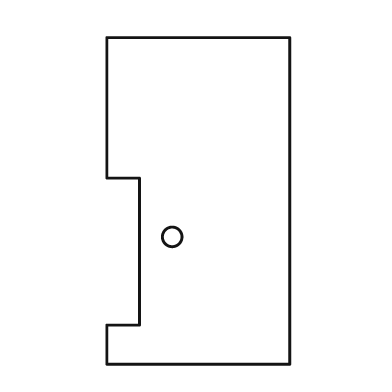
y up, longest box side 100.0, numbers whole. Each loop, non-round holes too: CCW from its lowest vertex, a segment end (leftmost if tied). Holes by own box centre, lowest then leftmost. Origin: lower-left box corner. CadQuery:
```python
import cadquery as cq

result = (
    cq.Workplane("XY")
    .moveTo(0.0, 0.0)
    .lineTo(56.0, 0.0)
    .lineTo(56.0, 100.0)
    .lineTo(0.0, 100.0)
    .lineTo(0.0, 57.0)
    .lineTo(10.0, 57.0)
    .lineTo(10.0, 12.0)
    .lineTo(0.0, 12.0)
    .close()
    .moveTo(20.0, 39.0)
    .circle(3.0)
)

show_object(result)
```